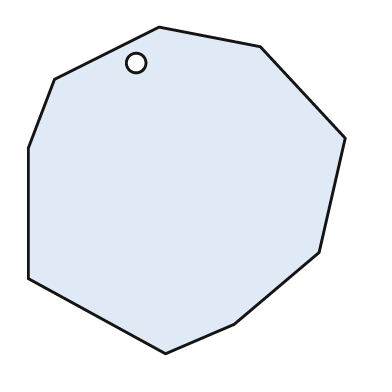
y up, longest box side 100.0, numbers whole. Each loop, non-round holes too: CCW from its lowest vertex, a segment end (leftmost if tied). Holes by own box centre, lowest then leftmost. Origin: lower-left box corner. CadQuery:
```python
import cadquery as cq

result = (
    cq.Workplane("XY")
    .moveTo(42.0, 0.0)
    .lineTo(63.0, 9.0)
    .lineTo(89.0, 31.0)
    .lineTo(97.0, 66.0)
    .lineTo(71.0, 94.0)
    .lineTo(40.0, 100.0)
    .lineTo(8.0, 84.0)
    .lineTo(0.0, 63.0)
    .lineTo(0.0, 23.0)
    .close()
    .moveTo(33.0, 89.0)
    .circle(3.0)
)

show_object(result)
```